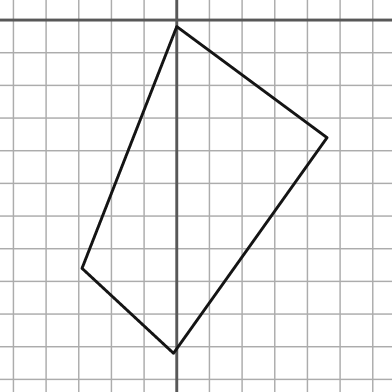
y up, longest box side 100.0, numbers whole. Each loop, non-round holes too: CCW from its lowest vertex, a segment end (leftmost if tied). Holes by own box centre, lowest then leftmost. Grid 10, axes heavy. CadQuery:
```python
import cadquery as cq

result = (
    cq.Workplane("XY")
    .moveTo(-1.0, -102.0)
    .lineTo(46.0, -36.0)
    .lineTo(0.0, -2.0)
    .lineTo(-29.0, -76.0)
    .close()
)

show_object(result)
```